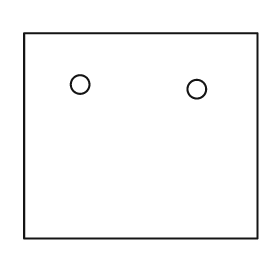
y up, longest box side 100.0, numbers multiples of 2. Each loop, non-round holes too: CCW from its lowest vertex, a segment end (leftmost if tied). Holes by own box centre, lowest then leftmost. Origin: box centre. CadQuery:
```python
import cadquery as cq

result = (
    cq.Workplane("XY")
    .moveTo(-50.0, -44.0)
    .lineTo(50.0, -44.0)
    .lineTo(50.0, 44.0)
    .lineTo(-50.0, 44.0)
    .close()
    .moveTo(24.0, 20.0)
    .circle(4.0)
    .moveTo(-26.0, 22.0)
    .circle(4.0)
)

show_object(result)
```